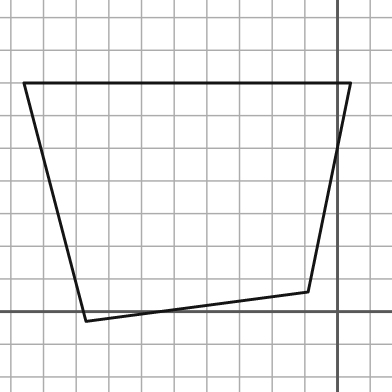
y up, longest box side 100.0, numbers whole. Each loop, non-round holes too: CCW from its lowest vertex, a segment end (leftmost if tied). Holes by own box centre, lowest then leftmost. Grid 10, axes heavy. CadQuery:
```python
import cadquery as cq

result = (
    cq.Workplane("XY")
    .moveTo(-77.0, -3.0)
    .lineTo(-9.0, 6.0)
    .lineTo(4.0, 70.0)
    .lineTo(-96.0, 70.0)
    .close()
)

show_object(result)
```